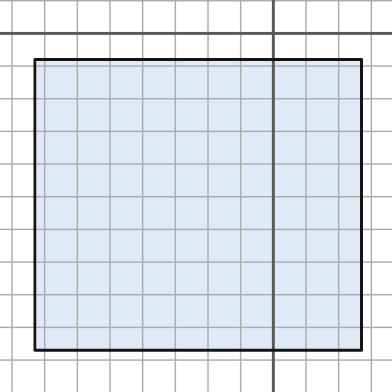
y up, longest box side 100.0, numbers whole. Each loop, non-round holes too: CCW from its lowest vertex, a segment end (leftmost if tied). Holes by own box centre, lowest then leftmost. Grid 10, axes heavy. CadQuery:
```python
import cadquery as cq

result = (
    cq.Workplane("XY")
    .moveTo(-73.0, -97.0)
    .lineTo(27.0, -97.0)
    .lineTo(27.0, -8.0)
    .lineTo(-73.0, -8.0)
    .close()
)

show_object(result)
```